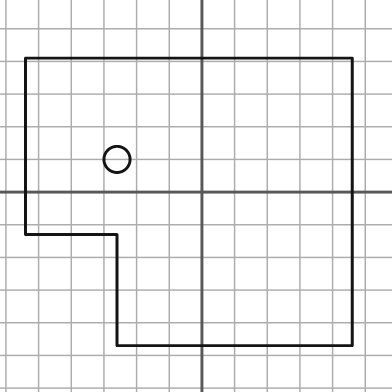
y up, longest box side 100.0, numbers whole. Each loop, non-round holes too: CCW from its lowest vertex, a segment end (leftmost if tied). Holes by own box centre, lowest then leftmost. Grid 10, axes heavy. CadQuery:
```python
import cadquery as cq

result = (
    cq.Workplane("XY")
    .moveTo(-26.0, -47.0)
    .lineTo(46.0, -47.0)
    .lineTo(46.0, 41.0)
    .lineTo(-54.0, 41.0)
    .lineTo(-54.0, -13.0)
    .lineTo(-26.0, -13.0)
    .close()
    .moveTo(-26.0, 10.0)
    .circle(4.0)
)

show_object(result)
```